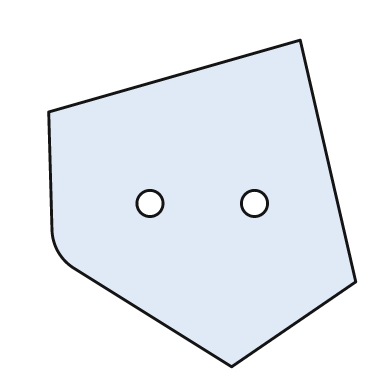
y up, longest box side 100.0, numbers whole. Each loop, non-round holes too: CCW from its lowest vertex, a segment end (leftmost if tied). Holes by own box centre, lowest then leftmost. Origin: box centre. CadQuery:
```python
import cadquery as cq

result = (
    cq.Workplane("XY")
    .moveTo(9.0, -50.0)
    .lineTo(47.0, -24.0)
    .lineTo(30.0, 50.0)
    .lineTo(-47.0, 28.0)
    .lineTo(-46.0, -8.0)
    .threePointArc((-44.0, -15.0), (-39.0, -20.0))
    .close()
    .moveTo(-16.0, 0.0)
    .circle(4.0)
    .moveTo(16.0, 0.0)
    .circle(4.0)
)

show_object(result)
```